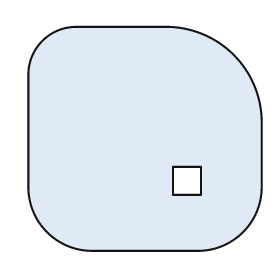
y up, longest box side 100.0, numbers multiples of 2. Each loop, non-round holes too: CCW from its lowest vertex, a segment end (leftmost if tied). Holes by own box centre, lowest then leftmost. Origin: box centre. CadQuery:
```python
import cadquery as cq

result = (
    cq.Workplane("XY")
    .moveTo(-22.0, -48.0)
    .lineTo(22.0, -48.0)
    .threePointArc((42.0, -40.0), (50.0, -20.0))
    .lineTo(50.0, 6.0)
    .threePointArc((38.0, 36.0), (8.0, 48.0))
    .lineTo(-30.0, 48.0)
    .threePointArc((-44.0, 42.0), (-50.0, 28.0))
    .lineTo(-50.0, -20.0)
    .threePointArc((-42.0, -40.0), (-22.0, -48.0))
    .close()
    .moveTo(12.0, -24.0)
    .lineTo(24.0, -24.0)
    .lineTo(24.0, -12.0)
    .lineTo(12.0, -12.0)
    .close()
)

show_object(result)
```